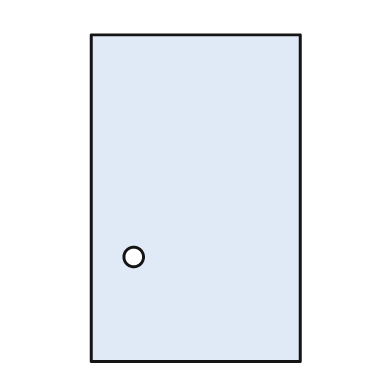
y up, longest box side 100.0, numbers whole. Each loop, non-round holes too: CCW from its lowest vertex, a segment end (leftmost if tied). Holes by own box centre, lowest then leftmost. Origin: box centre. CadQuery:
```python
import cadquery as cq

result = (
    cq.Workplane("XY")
    .moveTo(-32.0, -50.0)
    .lineTo(32.0, -50.0)
    .lineTo(32.0, 50.0)
    .lineTo(-32.0, 50.0)
    .close()
    .moveTo(-19.0, -18.0)
    .circle(3.0)
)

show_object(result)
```